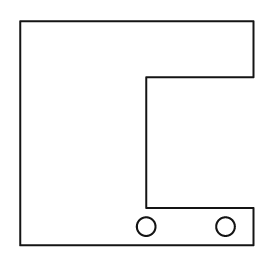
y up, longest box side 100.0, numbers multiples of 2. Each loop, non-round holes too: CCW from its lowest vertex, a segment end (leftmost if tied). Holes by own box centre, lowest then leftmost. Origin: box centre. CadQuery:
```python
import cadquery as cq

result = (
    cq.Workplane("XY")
    .moveTo(-50.0, -48.0)
    .lineTo(50.0, -48.0)
    .lineTo(50.0, -32.0)
    .lineTo(4.0, -32.0)
    .lineTo(4.0, 24.0)
    .lineTo(50.0, 24.0)
    .lineTo(50.0, 48.0)
    .lineTo(-50.0, 48.0)
    .close()
    .moveTo(4.0, -40.0)
    .circle(4.0)
    .moveTo(38.0, -40.0)
    .circle(4.0)
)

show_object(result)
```